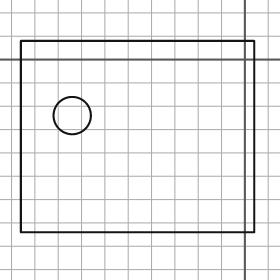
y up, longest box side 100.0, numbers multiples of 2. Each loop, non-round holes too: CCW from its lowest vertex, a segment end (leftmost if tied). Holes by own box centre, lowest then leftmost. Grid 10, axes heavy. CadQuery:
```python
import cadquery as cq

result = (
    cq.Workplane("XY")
    .moveTo(-96.0, -74.0)
    .lineTo(4.0, -74.0)
    .lineTo(4.0, 8.0)
    .lineTo(-96.0, 8.0)
    .close()
    .moveTo(-74.0, -24.0)
    .circle(8.0)
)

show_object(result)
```